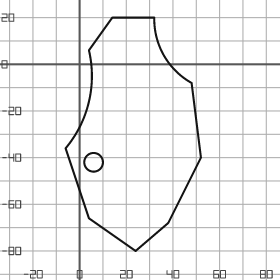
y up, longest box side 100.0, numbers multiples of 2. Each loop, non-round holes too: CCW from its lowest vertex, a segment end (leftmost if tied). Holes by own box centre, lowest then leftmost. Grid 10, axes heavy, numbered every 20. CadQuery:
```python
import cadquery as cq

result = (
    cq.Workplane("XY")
    .moveTo(24.0, -80.0)
    .lineTo(38.0, -68.0)
    .lineTo(52.0, -40.0)
    .lineTo(48.0, -8.0)
    .threePointArc((36.0, 4.0), (32.0, 20.0))
    .lineTo(14.0, 20.0)
    .lineTo(4.0, 6.0)
    .threePointArc((4.0, -16.0), (-6.0, -36.0))
    .lineTo(4.0, -66.0)
    .close()
    .moveTo(6.0, -42.0)
    .circle(4.0)
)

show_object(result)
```